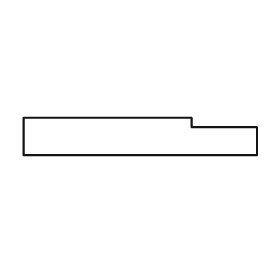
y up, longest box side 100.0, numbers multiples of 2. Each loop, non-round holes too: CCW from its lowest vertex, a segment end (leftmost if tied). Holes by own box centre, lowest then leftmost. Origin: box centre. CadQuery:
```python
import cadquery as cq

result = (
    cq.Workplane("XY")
    .moveTo(-50.0, -8.0)
    .lineTo(50.0, -8.0)
    .lineTo(50.0, 4.0)
    .lineTo(22.0, 4.0)
    .lineTo(22.0, 8.0)
    .lineTo(-50.0, 8.0)
    .close()
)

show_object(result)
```